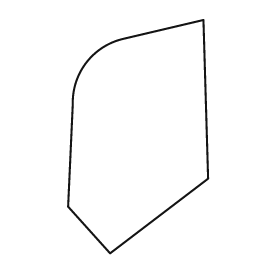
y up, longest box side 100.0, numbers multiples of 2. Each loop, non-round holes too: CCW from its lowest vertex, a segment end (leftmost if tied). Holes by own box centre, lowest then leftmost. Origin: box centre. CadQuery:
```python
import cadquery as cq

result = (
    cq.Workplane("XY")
    .moveTo(-12.0, -50.0)
    .lineTo(30.0, -18.0)
    .lineTo(28.0, 50.0)
    .lineTo(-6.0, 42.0)
    .threePointArc((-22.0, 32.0), (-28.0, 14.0))
    .lineTo(-30.0, -30.0)
    .close()
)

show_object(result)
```